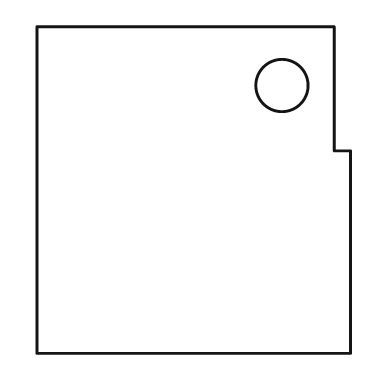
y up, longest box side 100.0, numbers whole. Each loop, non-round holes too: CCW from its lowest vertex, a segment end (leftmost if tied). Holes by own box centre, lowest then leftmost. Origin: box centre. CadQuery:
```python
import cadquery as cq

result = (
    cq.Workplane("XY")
    .moveTo(-48.0, -50.0)
    .lineTo(48.0, -50.0)
    .lineTo(48.0, 12.0)
    .lineTo(43.0, 12.0)
    .lineTo(43.0, 50.0)
    .lineTo(-48.0, 50.0)
    .close()
    .moveTo(27.0, 32.0)
    .circle(8.0)
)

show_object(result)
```